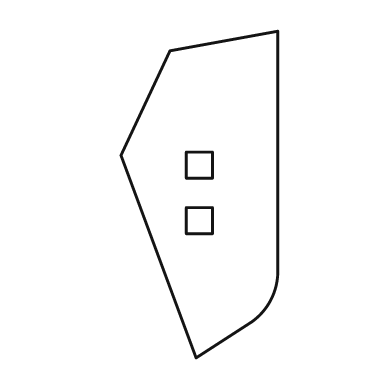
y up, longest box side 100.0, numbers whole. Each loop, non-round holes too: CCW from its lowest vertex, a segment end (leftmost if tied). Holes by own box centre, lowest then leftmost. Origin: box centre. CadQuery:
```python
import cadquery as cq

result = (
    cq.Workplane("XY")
    .moveTo(-1.0, -50.0)
    .lineTo(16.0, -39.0)
    .threePointArc((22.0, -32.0), (24.0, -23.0))
    .lineTo(24.0, 50.0)
    .lineTo(-9.0, 44.0)
    .lineTo(-24.0, 12.0)
    .close()
    .moveTo(-4.0, -12.0)
    .lineTo(4.0, -12.0)
    .lineTo(4.0, -4.0)
    .lineTo(-4.0, -4.0)
    .close()
    .moveTo(-4.0, 5.0)
    .lineTo(4.0, 5.0)
    .lineTo(4.0, 13.0)
    .lineTo(-4.0, 13.0)
    .close()
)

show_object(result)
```